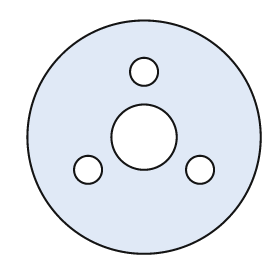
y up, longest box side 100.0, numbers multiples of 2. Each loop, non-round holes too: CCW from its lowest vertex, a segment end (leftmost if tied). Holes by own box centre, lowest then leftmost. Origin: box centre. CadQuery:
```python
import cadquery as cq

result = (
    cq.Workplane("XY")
    .moveTo(0.0, 0.0)
    .circle(50.0)
    .moveTo(-24.0, -14.0)
    .circle(6.0)
    .moveTo(24.0, -14.0)
    .circle(6.0)
    .moveTo(0.0, 0.0)
    .circle(14.0)
    .moveTo(0.0, 28.0)
    .circle(6.0)
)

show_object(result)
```